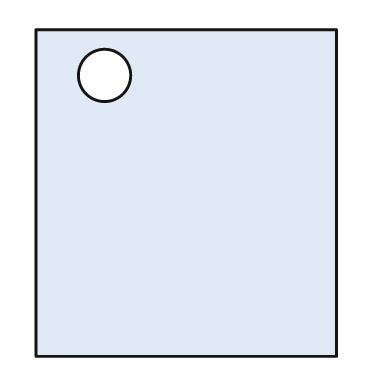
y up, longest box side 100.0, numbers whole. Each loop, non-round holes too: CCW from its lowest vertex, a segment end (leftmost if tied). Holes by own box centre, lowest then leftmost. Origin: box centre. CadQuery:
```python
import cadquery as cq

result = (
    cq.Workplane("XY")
    .moveTo(-46.0, -50.0)
    .lineTo(46.0, -50.0)
    .lineTo(46.0, 50.0)
    .lineTo(-46.0, 50.0)
    .close()
    .moveTo(-25.0, 36.0)
    .circle(8.0)
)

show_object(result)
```